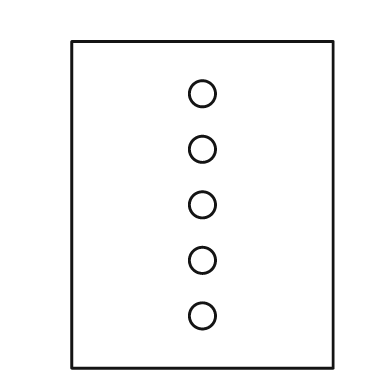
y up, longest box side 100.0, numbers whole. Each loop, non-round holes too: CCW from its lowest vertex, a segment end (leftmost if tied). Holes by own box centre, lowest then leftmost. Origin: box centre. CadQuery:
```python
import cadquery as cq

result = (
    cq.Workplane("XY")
    .moveTo(-40.0, -50.0)
    .lineTo(40.0, -50.0)
    .lineTo(40.0, 50.0)
    .lineTo(-40.0, 50.0)
    .close()
    .moveTo(0.0, -34.0)
    .circle(4.0)
    .moveTo(0.0, -17.0)
    .circle(4.0)
    .moveTo(0.0, 0.0)
    .circle(4.0)
    .moveTo(0.0, 17.0)
    .circle(4.0)
    .moveTo(0.0, 34.0)
    .circle(4.0)
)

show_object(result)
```